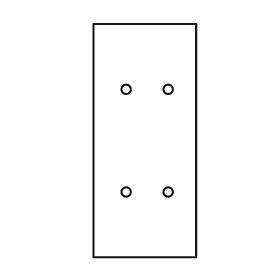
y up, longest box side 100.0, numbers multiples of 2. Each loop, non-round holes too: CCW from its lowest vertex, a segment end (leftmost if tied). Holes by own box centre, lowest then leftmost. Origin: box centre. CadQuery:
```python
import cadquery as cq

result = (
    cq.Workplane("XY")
    .moveTo(-22.0, -50.0)
    .lineTo(22.0, -50.0)
    .lineTo(22.0, 50.0)
    .lineTo(-22.0, 50.0)
    .close()
    .moveTo(-8.0, -22.0)
    .circle(2.0)
    .moveTo(10.0, -22.0)
    .circle(2.0)
    .moveTo(-8.0, 22.0)
    .circle(2.0)
    .moveTo(10.0, 22.0)
    .circle(2.0)
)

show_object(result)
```